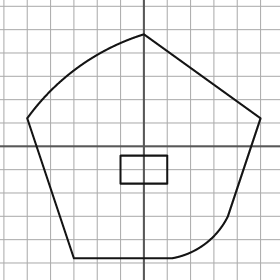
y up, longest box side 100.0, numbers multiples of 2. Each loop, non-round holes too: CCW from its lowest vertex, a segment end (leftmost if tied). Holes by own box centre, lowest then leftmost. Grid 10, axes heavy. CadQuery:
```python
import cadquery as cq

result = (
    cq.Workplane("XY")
    .moveTo(-30.0, -48.0)
    .lineTo(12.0, -48.0)
    .threePointArc((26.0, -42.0), (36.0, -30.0))
    .lineTo(50.0, 12.0)
    .lineTo(0.0, 48.0)
    .threePointArc((-28.0, 34.0), (-50.0, 12.0))
    .close()
    .moveTo(-10.0, -16.0)
    .lineTo(10.0, -16.0)
    .lineTo(10.0, -4.0)
    .lineTo(-10.0, -4.0)
    .close()
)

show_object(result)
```